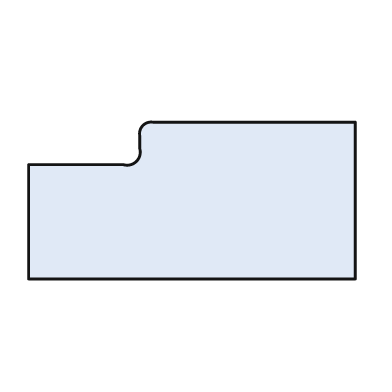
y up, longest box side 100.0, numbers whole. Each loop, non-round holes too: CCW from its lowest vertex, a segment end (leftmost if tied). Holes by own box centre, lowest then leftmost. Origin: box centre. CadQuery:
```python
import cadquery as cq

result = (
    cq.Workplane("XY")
    .moveTo(-50.0, -24.0)
    .lineTo(50.0, -24.0)
    .lineTo(50.0, 24.0)
    .lineTo(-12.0, 24.0)
    .threePointArc((-15.0, 23.0), (-16.0, 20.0))
    .lineTo(-16.0, 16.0)
    .threePointArc((-17.0, 12.0), (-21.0, 11.0))
    .lineTo(-50.0, 11.0)
    .close()
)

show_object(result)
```